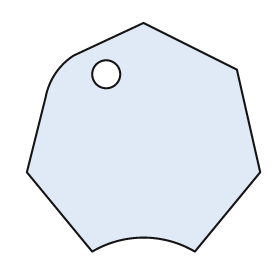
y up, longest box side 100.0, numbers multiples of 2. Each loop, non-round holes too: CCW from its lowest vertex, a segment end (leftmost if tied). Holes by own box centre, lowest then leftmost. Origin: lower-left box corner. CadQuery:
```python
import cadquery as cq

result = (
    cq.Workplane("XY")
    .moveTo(28.0, 0.0)
    .threePointArc((50.0, 6.0), (72.0, 0.0))
    .lineTo(100.0, 34.0)
    .lineTo(90.0, 78.0)
    .lineTo(50.0, 98.0)
    .lineTo(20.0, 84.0)
    .threePointArc((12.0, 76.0), (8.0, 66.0))
    .lineTo(0.0, 34.0)
    .close()
    .moveTo(34.0, 76.0)
    .circle(6.0)
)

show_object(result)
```